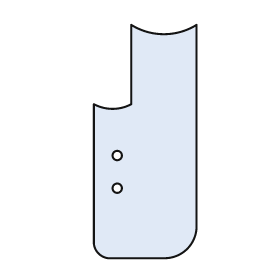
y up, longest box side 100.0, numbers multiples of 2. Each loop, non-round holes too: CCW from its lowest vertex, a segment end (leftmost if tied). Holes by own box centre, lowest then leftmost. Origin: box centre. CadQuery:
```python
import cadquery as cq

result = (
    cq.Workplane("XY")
    .moveTo(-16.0, -50.0)
    .lineTo(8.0, -50.0)
    .threePointArc((18.0, -46.0), (22.0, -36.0))
    .lineTo(22.0, 50.0)
    .threePointArc((8.0, 46.0), (-6.0, 50.0))
    .lineTo(-6.0, 16.0)
    .threePointArc((-14.0, 14.0), (-22.0, 16.0))
    .lineTo(-22.0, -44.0)
    .threePointArc((-20.0, -48.0), (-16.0, -50.0))
    .close()
    .moveTo(-12.0, -20.0)
    .circle(2.0)
    .moveTo(-12.0, -6.0)
    .circle(2.0)
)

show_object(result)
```